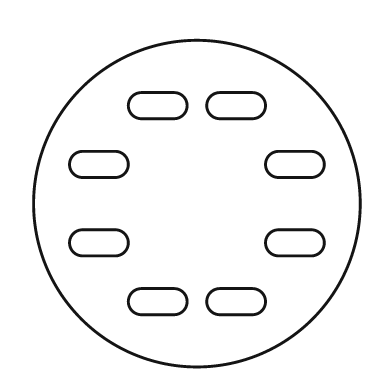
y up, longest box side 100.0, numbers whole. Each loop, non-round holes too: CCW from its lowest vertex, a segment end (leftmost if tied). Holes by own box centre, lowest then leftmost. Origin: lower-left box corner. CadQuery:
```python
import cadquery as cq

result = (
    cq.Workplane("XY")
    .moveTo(50.0, 50.0)
    .circle(50.0)
    .moveTo(33.0, 16.0)
    .lineTo(43.0, 16.0)
    .threePointArc((47.0, 20.0), (43.0, 24.0))
    .lineTo(33.0, 24.0)
    .threePointArc((29.0, 20.0), (33.0, 16.0))
    .close()
    .moveTo(57.0, 16.0)
    .lineTo(67.0, 16.0)
    .threePointArc((71.0, 20.0), (67.0, 24.0))
    .lineTo(57.0, 24.0)
    .threePointArc((53.0, 20.0), (57.0, 16.0))
    .close()
    .moveTo(15.0, 34.0)
    .lineTo(25.0, 34.0)
    .threePointArc((29.0, 38.0), (25.0, 42.0))
    .lineTo(15.0, 42.0)
    .threePointArc((11.0, 38.0), (15.0, 34.0))
    .close()
    .moveTo(75.0, 34.0)
    .lineTo(85.0, 34.0)
    .threePointArc((89.0, 38.0), (85.0, 42.0))
    .lineTo(75.0, 42.0)
    .threePointArc((71.0, 38.0), (75.0, 34.0))
    .close()
    .moveTo(15.0, 58.0)
    .lineTo(25.0, 58.0)
    .threePointArc((29.0, 62.0), (25.0, 66.0))
    .lineTo(15.0, 66.0)
    .threePointArc((11.0, 62.0), (15.0, 58.0))
    .close()
    .moveTo(75.0, 58.0)
    .lineTo(85.0, 58.0)
    .threePointArc((89.0, 62.0), (85.0, 66.0))
    .lineTo(75.0, 66.0)
    .threePointArc((71.0, 62.0), (75.0, 58.0))
    .close()
    .moveTo(33.0, 76.0)
    .lineTo(43.0, 76.0)
    .threePointArc((47.0, 80.0), (43.0, 84.0))
    .lineTo(33.0, 84.0)
    .threePointArc((29.0, 80.0), (33.0, 76.0))
    .close()
    .moveTo(57.0, 76.0)
    .lineTo(67.0, 76.0)
    .threePointArc((71.0, 80.0), (67.0, 84.0))
    .lineTo(57.0, 84.0)
    .threePointArc((53.0, 80.0), (57.0, 76.0))
    .close()
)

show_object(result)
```